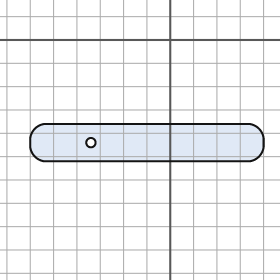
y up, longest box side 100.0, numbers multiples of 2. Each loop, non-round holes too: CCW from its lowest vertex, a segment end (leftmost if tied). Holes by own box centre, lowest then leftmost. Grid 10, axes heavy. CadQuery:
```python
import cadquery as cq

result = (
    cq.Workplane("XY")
    .moveTo(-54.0, -52.0)
    .lineTo(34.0, -52.0)
    .threePointArc((38.0, -50.0), (40.0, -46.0))
    .lineTo(40.0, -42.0)
    .threePointArc((38.0, -38.0), (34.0, -36.0))
    .lineTo(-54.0, -36.0)
    .threePointArc((-58.0, -38.0), (-60.0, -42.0))
    .lineTo(-60.0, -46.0)
    .threePointArc((-58.0, -50.0), (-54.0, -52.0))
    .close()
    .moveTo(-34.0, -44.0)
    .circle(2.0)
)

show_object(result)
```